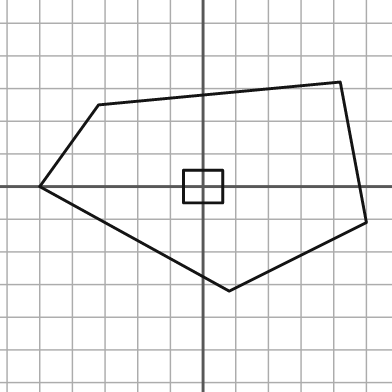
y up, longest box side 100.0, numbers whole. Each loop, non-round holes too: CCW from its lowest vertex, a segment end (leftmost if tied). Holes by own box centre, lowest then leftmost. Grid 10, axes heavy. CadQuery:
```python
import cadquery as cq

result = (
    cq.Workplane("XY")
    .moveTo(8.0, -32.0)
    .lineTo(50.0, -11.0)
    .lineTo(42.0, 32.0)
    .lineTo(-32.0, 25.0)
    .lineTo(-50.0, 0.0)
    .close()
    .moveTo(-6.0, -5.0)
    .lineTo(6.0, -5.0)
    .lineTo(6.0, 5.0)
    .lineTo(-6.0, 5.0)
    .close()
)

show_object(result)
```